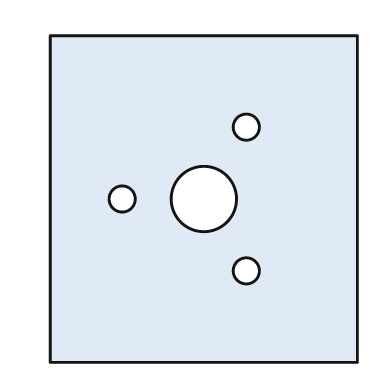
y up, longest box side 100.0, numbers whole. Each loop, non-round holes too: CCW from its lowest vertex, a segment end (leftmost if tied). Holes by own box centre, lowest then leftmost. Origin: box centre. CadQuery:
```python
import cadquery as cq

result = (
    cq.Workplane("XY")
    .moveTo(-47.0, -50.0)
    .lineTo(47.0, -50.0)
    .lineTo(47.0, 50.0)
    .lineTo(-47.0, 50.0)
    .close()
    .moveTo(13.0, -22.0)
    .circle(4.0)
    .moveTo(-25.0, 0.0)
    .circle(4.0)
    .moveTo(0.0, 0.0)
    .circle(10.0)
    .moveTo(13.0, 22.0)
    .circle(4.0)
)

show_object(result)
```